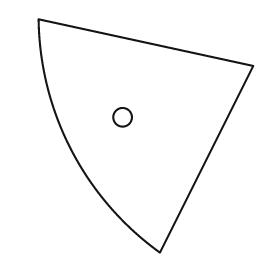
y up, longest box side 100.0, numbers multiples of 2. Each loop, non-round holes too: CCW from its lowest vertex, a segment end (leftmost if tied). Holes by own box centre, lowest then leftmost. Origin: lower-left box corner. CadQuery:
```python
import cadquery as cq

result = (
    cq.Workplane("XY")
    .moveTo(52.0, 0.0)
    .lineTo(92.0, 80.0)
    .lineTo(0.0, 100.0)
    .threePointArc((14.0, 44.0), (52.0, 0.0))
    .close()
    .moveTo(36.0, 58.0)
    .circle(4.0)
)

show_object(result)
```